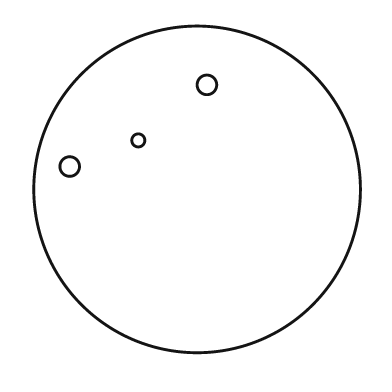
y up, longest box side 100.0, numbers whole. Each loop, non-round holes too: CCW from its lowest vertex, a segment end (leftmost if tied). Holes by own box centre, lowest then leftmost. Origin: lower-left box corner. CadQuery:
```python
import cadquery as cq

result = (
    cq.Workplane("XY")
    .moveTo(50.0, 50.0)
    .circle(50.0)
    .moveTo(11.0, 57.0)
    .circle(3.0)
    .moveTo(32.0, 65.0)
    .circle(2.0)
    .moveTo(53.0, 82.0)
    .circle(3.0)
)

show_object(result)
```